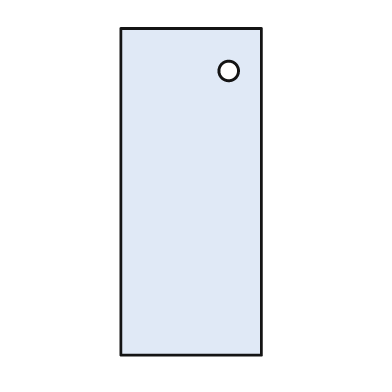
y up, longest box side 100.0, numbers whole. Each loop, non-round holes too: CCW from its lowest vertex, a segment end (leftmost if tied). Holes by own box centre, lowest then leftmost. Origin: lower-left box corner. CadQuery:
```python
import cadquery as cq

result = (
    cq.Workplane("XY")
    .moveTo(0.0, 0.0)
    .lineTo(43.0, 0.0)
    .lineTo(43.0, 100.0)
    .lineTo(0.0, 100.0)
    .close()
    .moveTo(33.0, 87.0)
    .circle(3.0)
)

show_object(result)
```